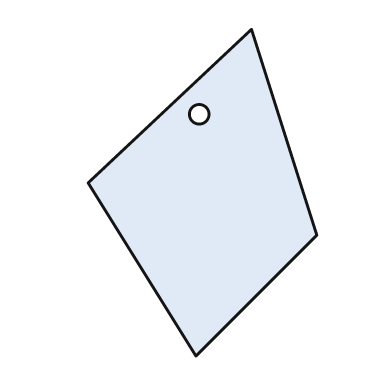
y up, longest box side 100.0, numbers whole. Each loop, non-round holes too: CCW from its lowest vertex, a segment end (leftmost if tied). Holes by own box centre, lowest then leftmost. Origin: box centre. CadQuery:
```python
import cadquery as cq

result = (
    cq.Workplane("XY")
    .moveTo(-2.0, -50.0)
    .lineTo(35.0, -13.0)
    .lineTo(15.0, 50.0)
    .lineTo(-35.0, 3.0)
    .close()
    .moveTo(-1.0, 24.0)
    .circle(3.0)
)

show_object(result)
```